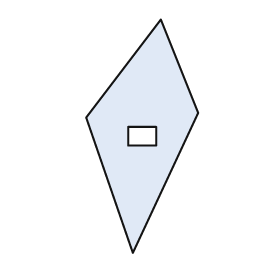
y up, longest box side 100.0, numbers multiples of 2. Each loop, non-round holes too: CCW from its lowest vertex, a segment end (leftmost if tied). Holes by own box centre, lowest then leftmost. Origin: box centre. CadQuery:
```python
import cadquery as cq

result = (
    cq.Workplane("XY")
    .moveTo(-4.0, -50.0)
    .lineTo(24.0, 10.0)
    .lineTo(8.0, 50.0)
    .lineTo(-24.0, 8.0)
    .close()
    .moveTo(-6.0, -4.0)
    .lineTo(6.0, -4.0)
    .lineTo(6.0, 4.0)
    .lineTo(-6.0, 4.0)
    .close()
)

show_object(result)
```